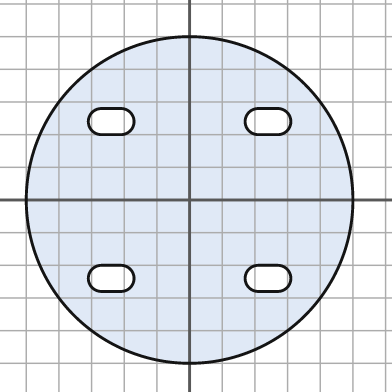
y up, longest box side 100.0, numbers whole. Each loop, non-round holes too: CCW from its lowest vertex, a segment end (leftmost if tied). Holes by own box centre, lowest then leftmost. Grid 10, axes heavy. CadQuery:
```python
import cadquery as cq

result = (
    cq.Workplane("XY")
    .moveTo(0.0, 0.0)
    .circle(50.0)
    .moveTo(-27.0, -28.0)
    .lineTo(-21.0, -28.0)
    .threePointArc((-17.0, -24.0), (-21.0, -20.0))
    .lineTo(-27.0, -20.0)
    .threePointArc((-31.0, -24.0), (-27.0, -28.0))
    .close()
    .moveTo(21.0, -28.0)
    .lineTo(27.0, -28.0)
    .threePointArc((31.0, -24.0), (27.0, -20.0))
    .lineTo(21.0, -20.0)
    .threePointArc((17.0, -24.0), (21.0, -28.0))
    .close()
    .moveTo(-27.0, 20.0)
    .lineTo(-21.0, 20.0)
    .threePointArc((-17.0, 24.0), (-21.0, 28.0))
    .lineTo(-27.0, 28.0)
    .threePointArc((-31.0, 24.0), (-27.0, 20.0))
    .close()
    .moveTo(21.0, 20.0)
    .lineTo(27.0, 20.0)
    .threePointArc((31.0, 24.0), (27.0, 28.0))
    .lineTo(21.0, 28.0)
    .threePointArc((17.0, 24.0), (21.0, 20.0))
    .close()
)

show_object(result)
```